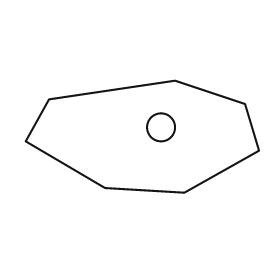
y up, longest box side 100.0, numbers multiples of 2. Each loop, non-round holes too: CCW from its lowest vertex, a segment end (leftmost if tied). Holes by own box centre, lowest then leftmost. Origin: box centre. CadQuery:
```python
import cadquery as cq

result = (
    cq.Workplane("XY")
    .moveTo(18.0, -24.0)
    .lineTo(50.0, -6.0)
    .lineTo(44.0, 14.0)
    .lineTo(14.0, 24.0)
    .lineTo(-40.0, 16.0)
    .lineTo(-50.0, -2.0)
    .lineTo(-16.0, -22.0)
    .close()
    .moveTo(8.0, 4.0)
    .circle(6.0)
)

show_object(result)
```